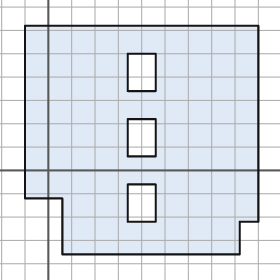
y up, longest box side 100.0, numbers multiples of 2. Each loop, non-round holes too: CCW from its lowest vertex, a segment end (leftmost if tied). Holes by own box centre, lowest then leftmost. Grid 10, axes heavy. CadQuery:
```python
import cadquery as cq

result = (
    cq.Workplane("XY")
    .moveTo(6.0, -36.0)
    .lineTo(82.0, -36.0)
    .lineTo(82.0, -22.0)
    .lineTo(90.0, -22.0)
    .lineTo(90.0, 62.0)
    .lineTo(-10.0, 62.0)
    .lineTo(-10.0, -12.0)
    .lineTo(6.0, -12.0)
    .close()
    .moveTo(34.0, -22.0)
    .lineTo(46.0, -22.0)
    .lineTo(46.0, -6.0)
    .lineTo(34.0, -6.0)
    .close()
    .moveTo(34.0, 6.0)
    .lineTo(46.0, 6.0)
    .lineTo(46.0, 22.0)
    .lineTo(34.0, 22.0)
    .close()
    .moveTo(34.0, 34.0)
    .lineTo(46.0, 34.0)
    .lineTo(46.0, 50.0)
    .lineTo(34.0, 50.0)
    .close()
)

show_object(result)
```